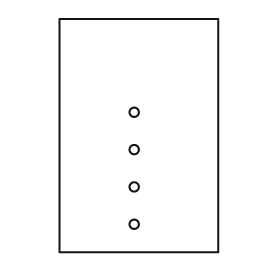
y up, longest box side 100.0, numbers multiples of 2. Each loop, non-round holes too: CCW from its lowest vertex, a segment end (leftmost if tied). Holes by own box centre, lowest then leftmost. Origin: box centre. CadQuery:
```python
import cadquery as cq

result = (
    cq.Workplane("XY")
    .moveTo(-34.0, -50.0)
    .lineTo(34.0, -50.0)
    .lineTo(34.0, 50.0)
    .lineTo(-34.0, 50.0)
    .close()
    .moveTo(-2.0, -38.0)
    .circle(2.0)
    .moveTo(-2.0, -22.0)
    .circle(2.0)
    .moveTo(-2.0, -6.0)
    .circle(2.0)
    .moveTo(-2.0, 10.0)
    .circle(2.0)
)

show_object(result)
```